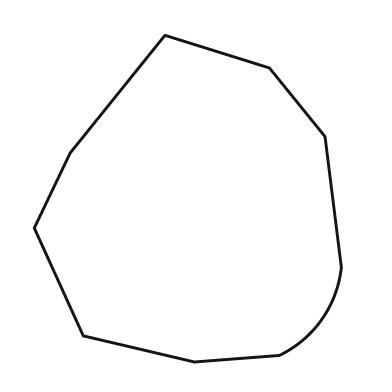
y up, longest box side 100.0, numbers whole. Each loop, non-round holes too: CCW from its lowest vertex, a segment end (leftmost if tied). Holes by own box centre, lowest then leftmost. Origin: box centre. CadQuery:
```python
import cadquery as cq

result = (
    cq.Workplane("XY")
    .moveTo(2.0, -50.0)
    .lineTo(28.0, -48.0)
    .threePointArc((41.0, -37.0), (47.0, -21.0))
    .lineTo(42.0, 19.0)
    .lineTo(25.0, 40.0)
    .lineTo(-7.0, 50.0)
    .lineTo(-36.0, 14.0)
    .lineTo(-47.0, -9.0)
    .lineTo(-32.0, -42.0)
    .close()
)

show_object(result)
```